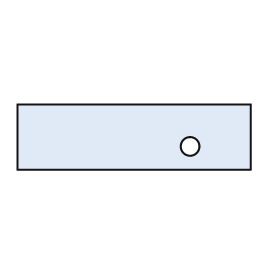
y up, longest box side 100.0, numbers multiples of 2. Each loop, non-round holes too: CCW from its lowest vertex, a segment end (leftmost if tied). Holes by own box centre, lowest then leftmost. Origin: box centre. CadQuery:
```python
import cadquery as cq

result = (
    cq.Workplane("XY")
    .moveTo(-50.0, -14.0)
    .lineTo(50.0, -14.0)
    .lineTo(50.0, 14.0)
    .lineTo(-50.0, 14.0)
    .close()
    .moveTo(24.0, -4.0)
    .circle(4.0)
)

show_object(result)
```